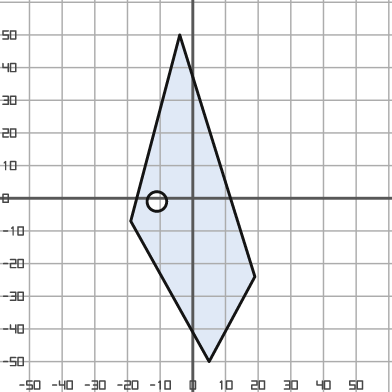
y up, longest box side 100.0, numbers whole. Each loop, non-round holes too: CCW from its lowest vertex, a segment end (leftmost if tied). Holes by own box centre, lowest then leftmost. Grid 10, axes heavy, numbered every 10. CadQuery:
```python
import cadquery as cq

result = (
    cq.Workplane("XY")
    .moveTo(5.0, -50.0)
    .lineTo(19.0, -24.0)
    .lineTo(-4.0, 50.0)
    .lineTo(-19.0, -7.0)
    .close()
    .moveTo(-11.0, -1.0)
    .circle(3.0)
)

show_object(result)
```